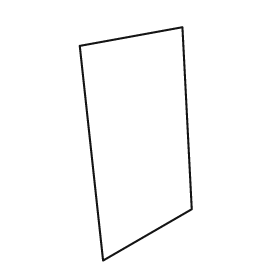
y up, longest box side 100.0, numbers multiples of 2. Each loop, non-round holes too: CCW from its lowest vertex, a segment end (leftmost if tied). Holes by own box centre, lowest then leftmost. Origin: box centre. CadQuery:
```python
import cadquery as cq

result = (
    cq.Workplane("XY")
    .moveTo(-14.0, -50.0)
    .lineTo(24.0, -28.0)
    .lineTo(20.0, 50.0)
    .lineTo(-24.0, 42.0)
    .close()
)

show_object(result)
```